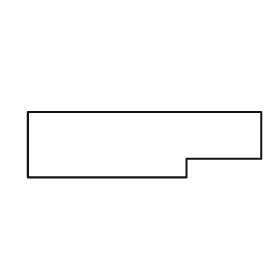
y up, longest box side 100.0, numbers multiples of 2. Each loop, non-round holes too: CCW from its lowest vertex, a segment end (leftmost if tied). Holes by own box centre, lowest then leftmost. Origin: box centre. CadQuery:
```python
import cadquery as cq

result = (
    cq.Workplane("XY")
    .moveTo(-50.0, -14.0)
    .lineTo(18.0, -14.0)
    .lineTo(18.0, -6.0)
    .lineTo(50.0, -6.0)
    .lineTo(50.0, 14.0)
    .lineTo(-50.0, 14.0)
    .close()
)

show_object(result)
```